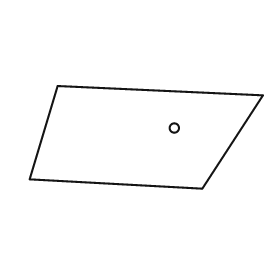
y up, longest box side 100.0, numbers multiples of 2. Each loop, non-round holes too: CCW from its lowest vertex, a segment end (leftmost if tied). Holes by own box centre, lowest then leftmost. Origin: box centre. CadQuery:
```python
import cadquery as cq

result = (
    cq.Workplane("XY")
    .moveTo(24.0, -22.0)
    .lineTo(50.0, 18.0)
    .lineTo(-38.0, 22.0)
    .lineTo(-50.0, -18.0)
    .close()
    .moveTo(12.0, 4.0)
    .circle(2.0)
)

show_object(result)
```